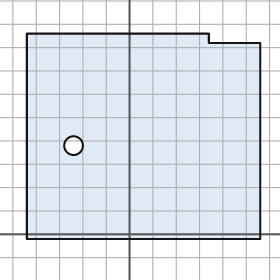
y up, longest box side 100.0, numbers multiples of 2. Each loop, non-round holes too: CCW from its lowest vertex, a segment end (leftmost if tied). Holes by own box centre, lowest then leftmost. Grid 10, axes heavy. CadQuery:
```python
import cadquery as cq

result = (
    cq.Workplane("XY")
    .moveTo(-44.0, -2.0)
    .lineTo(56.0, -2.0)
    .lineTo(56.0, 82.0)
    .lineTo(34.0, 82.0)
    .lineTo(34.0, 86.0)
    .lineTo(-44.0, 86.0)
    .close()
    .moveTo(-24.0, 38.0)
    .circle(4.0)
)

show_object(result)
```